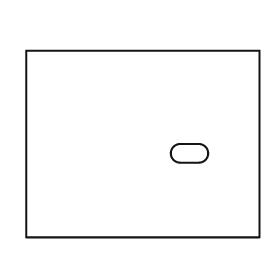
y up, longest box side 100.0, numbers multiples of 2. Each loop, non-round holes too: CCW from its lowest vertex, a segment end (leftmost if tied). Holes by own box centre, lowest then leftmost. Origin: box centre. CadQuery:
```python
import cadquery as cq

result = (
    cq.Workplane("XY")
    .moveTo(-50.0, -40.0)
    .lineTo(50.0, -40.0)
    .lineTo(50.0, 40.0)
    .lineTo(-50.0, 40.0)
    .close()
    .moveTo(16.0, -8.0)
    .lineTo(24.0, -8.0)
    .threePointArc((28.0, -4.0), (24.0, 0.0))
    .lineTo(16.0, 0.0)
    .threePointArc((12.0, -4.0), (16.0, -8.0))
    .close()
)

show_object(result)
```